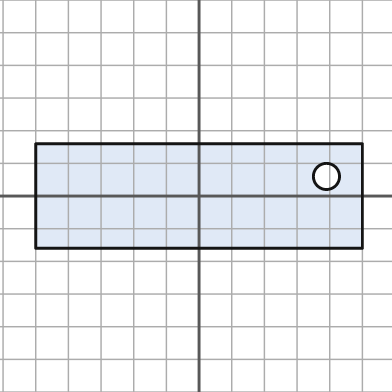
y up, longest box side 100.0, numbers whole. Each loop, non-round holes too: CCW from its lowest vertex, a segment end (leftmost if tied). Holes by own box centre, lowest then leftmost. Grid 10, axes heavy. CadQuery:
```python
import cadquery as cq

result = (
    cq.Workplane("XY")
    .moveTo(-50.0, -16.0)
    .lineTo(50.0, -16.0)
    .lineTo(50.0, 16.0)
    .lineTo(-50.0, 16.0)
    .close()
    .moveTo(39.0, 6.0)
    .circle(4.0)
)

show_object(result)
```